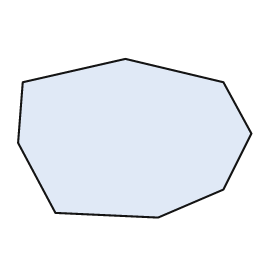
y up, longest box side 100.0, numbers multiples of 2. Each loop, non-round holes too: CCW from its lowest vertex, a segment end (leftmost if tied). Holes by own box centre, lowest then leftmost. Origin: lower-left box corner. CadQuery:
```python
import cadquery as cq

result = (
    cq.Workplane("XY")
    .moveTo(60.0, 0.0)
    .lineTo(88.0, 12.0)
    .lineTo(100.0, 36.0)
    .lineTo(88.0, 58.0)
    .lineTo(46.0, 68.0)
    .lineTo(2.0, 58.0)
    .lineTo(0.0, 32.0)
    .lineTo(16.0, 2.0)
    .close()
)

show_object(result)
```